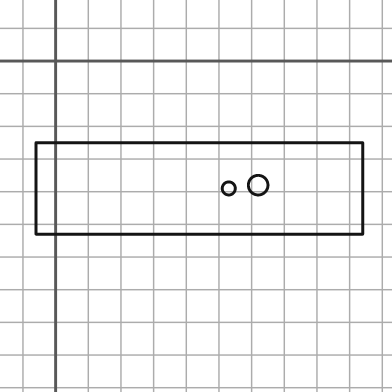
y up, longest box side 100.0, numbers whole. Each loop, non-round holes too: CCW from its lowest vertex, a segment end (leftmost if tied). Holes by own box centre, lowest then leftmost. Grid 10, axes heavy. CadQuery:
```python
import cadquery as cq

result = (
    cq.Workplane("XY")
    .moveTo(-6.0, -53.0)
    .lineTo(94.0, -53.0)
    .lineTo(94.0, -25.0)
    .lineTo(-6.0, -25.0)
    .close()
    .moveTo(53.0, -39.0)
    .circle(2.0)
    .moveTo(62.0, -38.0)
    .circle(3.0)
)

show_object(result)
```